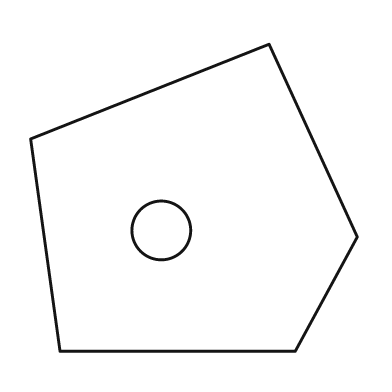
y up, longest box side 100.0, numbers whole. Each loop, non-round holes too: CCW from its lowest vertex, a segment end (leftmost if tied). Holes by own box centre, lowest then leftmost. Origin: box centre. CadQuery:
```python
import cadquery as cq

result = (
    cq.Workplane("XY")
    .moveTo(-41.0, -47.0)
    .lineTo(31.0, -47.0)
    .lineTo(50.0, -12.0)
    .lineTo(23.0, 47.0)
    .lineTo(-50.0, 18.0)
    .close()
    .moveTo(-10.0, -10.0)
    .circle(9.0)
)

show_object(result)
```